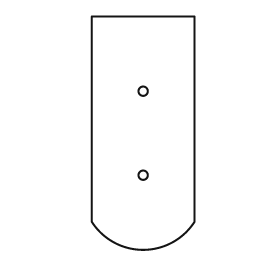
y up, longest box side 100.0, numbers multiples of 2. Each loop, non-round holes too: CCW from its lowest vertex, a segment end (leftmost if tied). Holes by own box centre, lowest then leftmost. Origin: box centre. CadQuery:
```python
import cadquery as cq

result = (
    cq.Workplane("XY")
    .moveTo(-22.0, -38.0)
    .threePointArc((0.0, -50.0), (22.0, -38.0))
    .lineTo(22.0, 50.0)
    .lineTo(-22.0, 50.0)
    .close()
    .moveTo(0.0, -18.0)
    .circle(2.0)
    .moveTo(0.0, 18.0)
    .circle(2.0)
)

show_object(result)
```